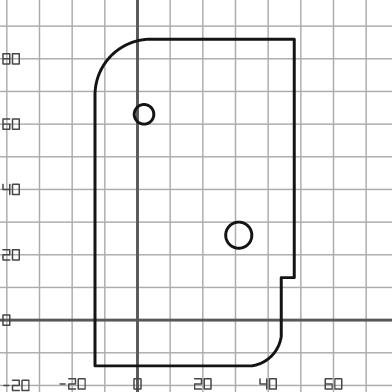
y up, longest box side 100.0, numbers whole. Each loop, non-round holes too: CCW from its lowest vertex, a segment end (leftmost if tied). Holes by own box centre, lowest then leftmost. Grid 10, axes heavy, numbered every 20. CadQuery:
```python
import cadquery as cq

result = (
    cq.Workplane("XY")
    .moveTo(-13.0, -14.0)
    .lineTo(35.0, -14.0)
    .threePointArc((41.0, -11.0), (44.0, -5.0))
    .lineTo(44.0, 13.0)
    .lineTo(48.0, 13.0)
    .lineTo(48.0, 86.0)
    .lineTo(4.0, 86.0)
    .threePointArc((-8.0, 81.0), (-13.0, 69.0))
    .close()
    .moveTo(31.0, 26.0)
    .circle(4.0)
    .moveTo(2.0, 63.0)
    .circle(3.0)
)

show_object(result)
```